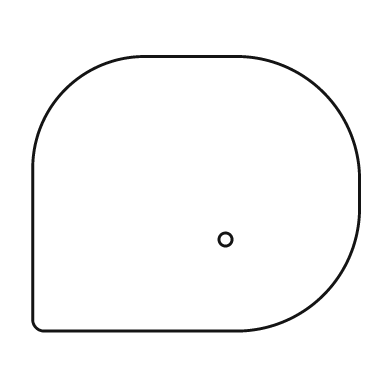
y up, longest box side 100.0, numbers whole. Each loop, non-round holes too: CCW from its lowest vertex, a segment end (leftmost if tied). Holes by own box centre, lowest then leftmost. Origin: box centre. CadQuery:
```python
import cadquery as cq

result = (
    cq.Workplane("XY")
    .moveTo(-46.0, -42.0)
    .lineTo(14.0, -42.0)
    .threePointArc((39.0, -31.0), (50.0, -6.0))
    .lineTo(50.0, 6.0)
    .threePointArc((39.0, 31.0), (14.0, 42.0))
    .lineTo(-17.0, 42.0)
    .threePointArc((-40.0, 32.0), (-50.0, 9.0))
    .lineTo(-50.0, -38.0)
    .threePointArc((-49.0, -41.0), (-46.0, -42.0))
    .close()
    .moveTo(9.0, -14.0)
    .circle(2.0)
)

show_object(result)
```